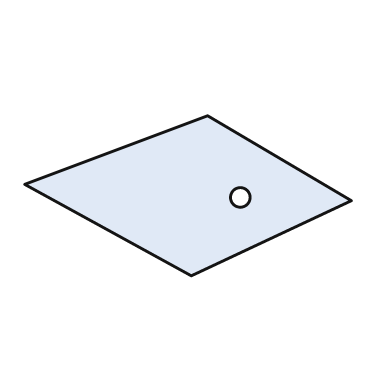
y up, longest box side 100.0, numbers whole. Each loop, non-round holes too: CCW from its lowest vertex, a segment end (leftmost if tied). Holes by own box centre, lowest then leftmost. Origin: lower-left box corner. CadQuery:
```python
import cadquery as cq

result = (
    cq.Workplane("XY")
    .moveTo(51.0, 0.0)
    .lineTo(100.0, 23.0)
    .lineTo(56.0, 49.0)
    .lineTo(0.0, 28.0)
    .close()
    .moveTo(66.0, 24.0)
    .circle(3.0)
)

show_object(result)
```